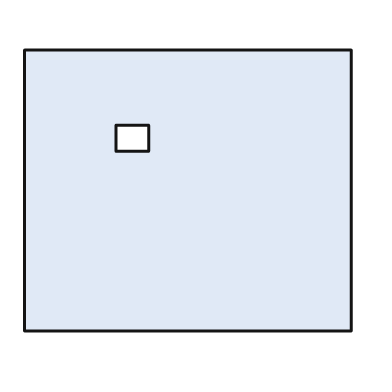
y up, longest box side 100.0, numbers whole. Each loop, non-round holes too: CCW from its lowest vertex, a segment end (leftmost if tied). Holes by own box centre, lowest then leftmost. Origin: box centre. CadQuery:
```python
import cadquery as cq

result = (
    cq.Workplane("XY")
    .moveTo(-50.0, -43.0)
    .lineTo(50.0, -43.0)
    .lineTo(50.0, 43.0)
    .lineTo(-50.0, 43.0)
    .close()
    .moveTo(-22.0, 12.0)
    .lineTo(-12.0, 12.0)
    .lineTo(-12.0, 20.0)
    .lineTo(-22.0, 20.0)
    .close()
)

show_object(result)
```